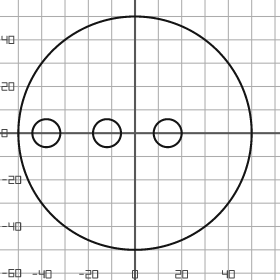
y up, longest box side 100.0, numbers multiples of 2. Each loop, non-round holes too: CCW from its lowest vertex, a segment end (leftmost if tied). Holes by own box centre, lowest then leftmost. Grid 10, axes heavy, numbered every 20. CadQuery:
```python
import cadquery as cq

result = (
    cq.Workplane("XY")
    .moveTo(0.0, 0.0)
    .circle(50.0)
    .moveTo(-38.0, 0.0)
    .circle(6.0)
    .moveTo(-12.0, 0.0)
    .circle(6.0)
    .moveTo(14.0, 0.0)
    .circle(6.0)
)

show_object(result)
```